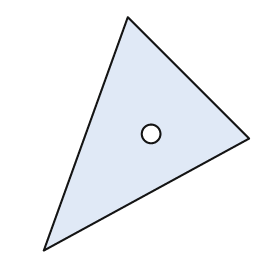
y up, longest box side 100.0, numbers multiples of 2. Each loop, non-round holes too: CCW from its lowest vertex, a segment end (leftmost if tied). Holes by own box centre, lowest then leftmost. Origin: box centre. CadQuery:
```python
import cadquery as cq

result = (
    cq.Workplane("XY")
    .moveTo(-44.0, -50.0)
    .lineTo(44.0, -2.0)
    .lineTo(-8.0, 50.0)
    .close()
    .moveTo(2.0, 0.0)
    .circle(4.0)
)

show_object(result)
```